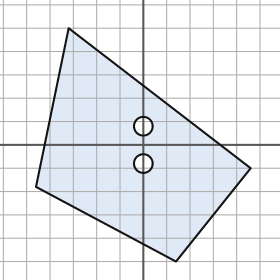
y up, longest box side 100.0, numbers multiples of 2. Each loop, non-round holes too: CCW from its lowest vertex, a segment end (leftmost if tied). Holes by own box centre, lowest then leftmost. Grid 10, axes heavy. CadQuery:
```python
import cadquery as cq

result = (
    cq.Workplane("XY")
    .moveTo(14.0, -50.0)
    .lineTo(46.0, -10.0)
    .lineTo(-32.0, 50.0)
    .lineTo(-46.0, -18.0)
    .close()
    .moveTo(0.0, -8.0)
    .circle(4.0)
    .moveTo(0.0, 8.0)
    .circle(4.0)
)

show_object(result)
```